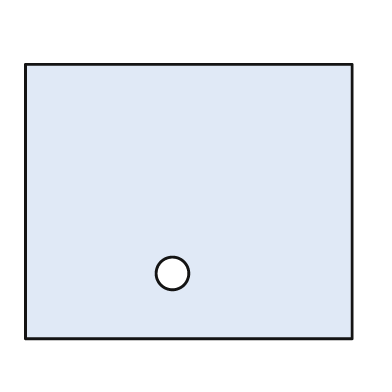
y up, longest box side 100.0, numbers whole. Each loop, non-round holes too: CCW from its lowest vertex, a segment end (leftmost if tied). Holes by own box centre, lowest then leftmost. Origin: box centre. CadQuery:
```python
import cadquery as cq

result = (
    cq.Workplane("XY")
    .moveTo(-50.0, -42.0)
    .lineTo(50.0, -42.0)
    .lineTo(50.0, 42.0)
    .lineTo(-50.0, 42.0)
    .close()
    .moveTo(-5.0, -22.0)
    .circle(5.0)
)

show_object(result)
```